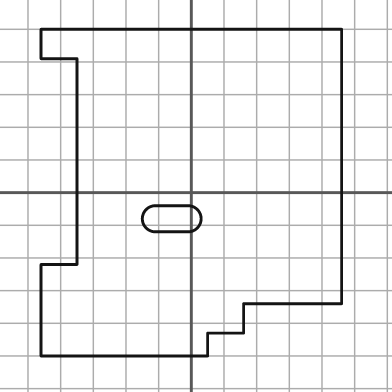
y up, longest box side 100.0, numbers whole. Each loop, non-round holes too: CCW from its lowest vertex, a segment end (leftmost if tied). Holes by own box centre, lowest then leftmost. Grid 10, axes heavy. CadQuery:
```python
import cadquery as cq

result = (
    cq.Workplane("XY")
    .moveTo(-46.0, -50.0)
    .lineTo(5.0, -50.0)
    .lineTo(5.0, -43.0)
    .lineTo(16.0, -43.0)
    .lineTo(16.0, -34.0)
    .lineTo(46.0, -34.0)
    .lineTo(46.0, 50.0)
    .lineTo(-46.0, 50.0)
    .lineTo(-46.0, 41.0)
    .lineTo(-35.0, 41.0)
    .lineTo(-35.0, -22.0)
    .lineTo(-46.0, -22.0)
    .close()
    .moveTo(-11.0, -12.0)
    .lineTo(-1.0, -12.0)
    .threePointArc((3.0, -8.0), (-1.0, -4.0))
    .lineTo(-11.0, -4.0)
    .threePointArc((-15.0, -8.0), (-11.0, -12.0))
    .close()
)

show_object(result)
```